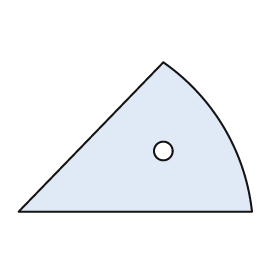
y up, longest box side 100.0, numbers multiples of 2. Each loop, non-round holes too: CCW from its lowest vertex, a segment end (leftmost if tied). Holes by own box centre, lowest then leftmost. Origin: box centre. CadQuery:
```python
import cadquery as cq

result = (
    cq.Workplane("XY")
    .moveTo(-50.0, -32.0)
    .lineTo(50.0, -32.0)
    .threePointArc((38.0, 4.0), (12.0, 32.0))
    .close()
    .moveTo(12.0, -6.0)
    .circle(4.0)
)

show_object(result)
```